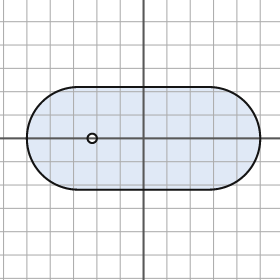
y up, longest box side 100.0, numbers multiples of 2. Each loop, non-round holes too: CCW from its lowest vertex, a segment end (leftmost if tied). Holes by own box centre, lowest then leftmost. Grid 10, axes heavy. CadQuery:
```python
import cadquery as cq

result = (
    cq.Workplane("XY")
    .moveTo(-28.0, -22.0)
    .lineTo(28.0, -22.0)
    .threePointArc((50.0, 0.0), (28.0, 22.0))
    .lineTo(-28.0, 22.0)
    .threePointArc((-50.0, 0.0), (-28.0, -22.0))
    .close()
    .moveTo(-22.0, 0.0)
    .circle(2.0)
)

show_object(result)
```